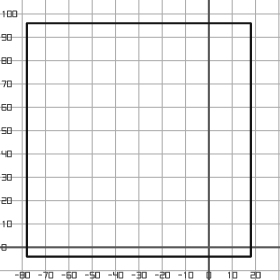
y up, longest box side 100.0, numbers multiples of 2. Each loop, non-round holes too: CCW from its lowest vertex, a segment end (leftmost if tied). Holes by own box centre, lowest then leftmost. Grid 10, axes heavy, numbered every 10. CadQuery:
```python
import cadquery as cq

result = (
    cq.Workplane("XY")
    .moveTo(-78.0, -4.0)
    .lineTo(18.0, -4.0)
    .lineTo(18.0, 96.0)
    .lineTo(-78.0, 96.0)
    .close()
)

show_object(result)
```